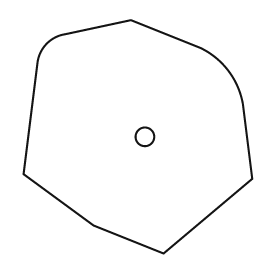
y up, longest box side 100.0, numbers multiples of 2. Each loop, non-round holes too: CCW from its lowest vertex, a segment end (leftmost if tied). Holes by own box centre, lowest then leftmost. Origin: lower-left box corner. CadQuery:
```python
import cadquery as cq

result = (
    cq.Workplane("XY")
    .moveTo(60.0, 0.0)
    .lineTo(98.0, 32.0)
    .lineTo(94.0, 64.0)
    .threePointArc((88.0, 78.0), (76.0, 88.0))
    .lineTo(46.0, 100.0)
    .lineTo(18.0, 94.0)
    .threePointArc((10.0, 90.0), (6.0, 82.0))
    .lineTo(0.0, 34.0)
    .lineTo(30.0, 12.0)
    .close()
    .moveTo(52.0, 50.0)
    .circle(4.0)
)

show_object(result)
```